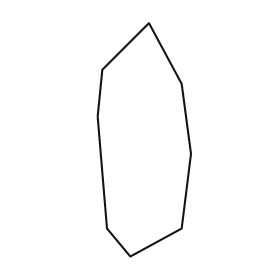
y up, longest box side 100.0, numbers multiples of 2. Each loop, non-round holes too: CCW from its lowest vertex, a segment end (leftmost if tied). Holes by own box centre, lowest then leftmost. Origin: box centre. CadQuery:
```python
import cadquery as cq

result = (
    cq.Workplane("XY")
    .moveTo(-6.0, -50.0)
    .lineTo(16.0, -38.0)
    .lineTo(20.0, -6.0)
    .lineTo(16.0, 24.0)
    .lineTo(2.0, 50.0)
    .lineTo(-18.0, 30.0)
    .lineTo(-20.0, 10.0)
    .lineTo(-16.0, -38.0)
    .close()
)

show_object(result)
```